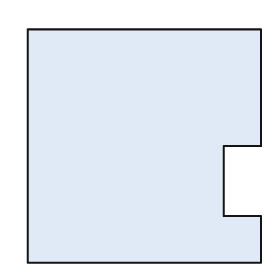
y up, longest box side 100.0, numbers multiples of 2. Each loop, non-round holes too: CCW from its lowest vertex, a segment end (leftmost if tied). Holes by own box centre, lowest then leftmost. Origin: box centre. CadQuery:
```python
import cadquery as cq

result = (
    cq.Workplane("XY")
    .moveTo(-50.0, -50.0)
    .lineTo(50.0, -50.0)
    .lineTo(50.0, -30.0)
    .lineTo(34.0, -30.0)
    .lineTo(34.0, 0.0)
    .lineTo(50.0, 0.0)
    .lineTo(50.0, 50.0)
    .lineTo(-50.0, 50.0)
    .close()
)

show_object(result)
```